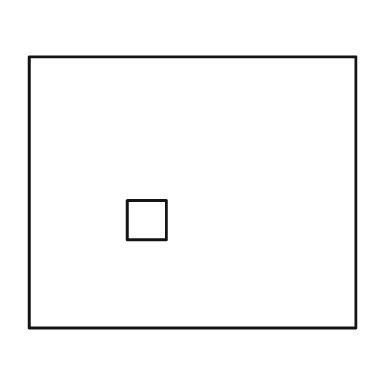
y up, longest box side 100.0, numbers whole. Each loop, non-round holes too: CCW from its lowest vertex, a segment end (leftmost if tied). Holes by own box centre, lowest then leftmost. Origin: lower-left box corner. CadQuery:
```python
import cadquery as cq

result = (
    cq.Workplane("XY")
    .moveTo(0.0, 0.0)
    .lineTo(100.0, 0.0)
    .lineTo(100.0, 83.0)
    .lineTo(0.0, 83.0)
    .close()
    .moveTo(30.0, 27.0)
    .lineTo(42.0, 27.0)
    .lineTo(42.0, 39.0)
    .lineTo(30.0, 39.0)
    .close()
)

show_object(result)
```